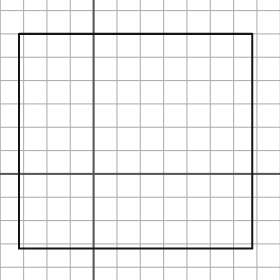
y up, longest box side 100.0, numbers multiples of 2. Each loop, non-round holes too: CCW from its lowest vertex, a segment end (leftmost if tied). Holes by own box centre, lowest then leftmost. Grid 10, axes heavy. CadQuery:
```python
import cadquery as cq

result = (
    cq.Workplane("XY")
    .moveTo(-32.0, -32.0)
    .lineTo(68.0, -32.0)
    .lineTo(68.0, 60.0)
    .lineTo(-32.0, 60.0)
    .close()
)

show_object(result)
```